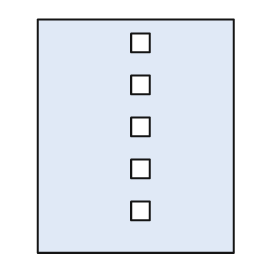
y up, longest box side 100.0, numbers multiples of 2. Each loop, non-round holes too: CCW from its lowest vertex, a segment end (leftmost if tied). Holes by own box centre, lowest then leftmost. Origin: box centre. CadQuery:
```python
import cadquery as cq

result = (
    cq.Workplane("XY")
    .moveTo(-42.0, -50.0)
    .lineTo(42.0, -50.0)
    .lineTo(42.0, 50.0)
    .lineTo(-42.0, 50.0)
    .close()
    .moveTo(-2.0, -36.0)
    .lineTo(6.0, -36.0)
    .lineTo(6.0, -28.0)
    .lineTo(-2.0, -28.0)
    .close()
    .moveTo(-2.0, -18.0)
    .lineTo(6.0, -18.0)
    .lineTo(6.0, -10.0)
    .lineTo(-2.0, -10.0)
    .close()
    .moveTo(-2.0, 0.0)
    .lineTo(6.0, 0.0)
    .lineTo(6.0, 8.0)
    .lineTo(-2.0, 8.0)
    .close()
    .moveTo(-2.0, 18.0)
    .lineTo(6.0, 18.0)
    .lineTo(6.0, 26.0)
    .lineTo(-2.0, 26.0)
    .close()
    .moveTo(-2.0, 36.0)
    .lineTo(6.0, 36.0)
    .lineTo(6.0, 44.0)
    .lineTo(-2.0, 44.0)
    .close()
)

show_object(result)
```